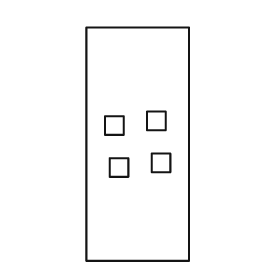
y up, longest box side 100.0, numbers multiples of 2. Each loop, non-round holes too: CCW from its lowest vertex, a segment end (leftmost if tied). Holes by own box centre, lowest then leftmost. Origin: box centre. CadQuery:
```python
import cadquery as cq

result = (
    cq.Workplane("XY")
    .moveTo(-22.0, -50.0)
    .lineTo(22.0, -50.0)
    .lineTo(22.0, 50.0)
    .lineTo(-22.0, 50.0)
    .close()
    .moveTo(-12.0, -14.0)
    .lineTo(-4.0, -14.0)
    .lineTo(-4.0, -6.0)
    .lineTo(-12.0, -6.0)
    .close()
    .moveTo(6.0, -12.0)
    .lineTo(14.0, -12.0)
    .lineTo(14.0, -4.0)
    .lineTo(6.0, -4.0)
    .close()
    .moveTo(-14.0, 4.0)
    .lineTo(-6.0, 4.0)
    .lineTo(-6.0, 12.0)
    .lineTo(-14.0, 12.0)
    .close()
    .moveTo(4.0, 6.0)
    .lineTo(12.0, 6.0)
    .lineTo(12.0, 14.0)
    .lineTo(4.0, 14.0)
    .close()
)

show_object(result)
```